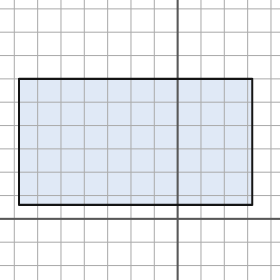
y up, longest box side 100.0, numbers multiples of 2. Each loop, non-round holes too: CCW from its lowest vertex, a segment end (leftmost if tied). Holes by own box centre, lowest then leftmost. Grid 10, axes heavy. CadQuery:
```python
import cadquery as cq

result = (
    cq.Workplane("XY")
    .moveTo(-68.0, 6.0)
    .lineTo(32.0, 6.0)
    .lineTo(32.0, 60.0)
    .lineTo(-68.0, 60.0)
    .close()
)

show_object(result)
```